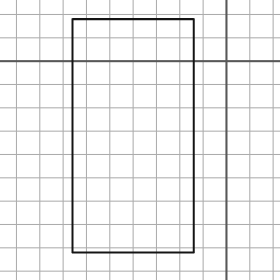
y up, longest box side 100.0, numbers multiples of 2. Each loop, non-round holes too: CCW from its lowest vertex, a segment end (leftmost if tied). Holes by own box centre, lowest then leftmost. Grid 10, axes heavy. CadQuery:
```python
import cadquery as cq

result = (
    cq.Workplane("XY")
    .moveTo(-66.0, -82.0)
    .lineTo(-14.0, -82.0)
    .lineTo(-14.0, 18.0)
    .lineTo(-66.0, 18.0)
    .close()
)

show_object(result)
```